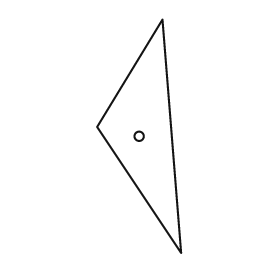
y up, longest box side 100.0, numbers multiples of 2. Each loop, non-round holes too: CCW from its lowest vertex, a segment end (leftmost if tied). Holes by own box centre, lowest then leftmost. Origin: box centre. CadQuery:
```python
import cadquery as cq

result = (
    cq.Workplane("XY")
    .moveTo(18.0, -50.0)
    .lineTo(10.0, 50.0)
    .lineTo(-18.0, 4.0)
    .close()
    .moveTo(0.0, 0.0)
    .circle(2.0)
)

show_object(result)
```